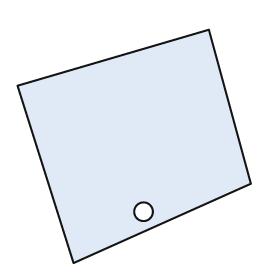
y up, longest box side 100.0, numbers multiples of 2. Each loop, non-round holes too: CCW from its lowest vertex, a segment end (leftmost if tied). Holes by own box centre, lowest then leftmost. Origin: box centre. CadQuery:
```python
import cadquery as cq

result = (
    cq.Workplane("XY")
    .moveTo(-26.0, -50.0)
    .lineTo(50.0, -16.0)
    .lineTo(32.0, 50.0)
    .lineTo(-50.0, 26.0)
    .close()
    .moveTo(4.0, -28.0)
    .circle(4.0)
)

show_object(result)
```